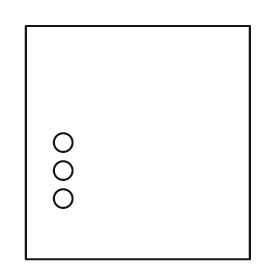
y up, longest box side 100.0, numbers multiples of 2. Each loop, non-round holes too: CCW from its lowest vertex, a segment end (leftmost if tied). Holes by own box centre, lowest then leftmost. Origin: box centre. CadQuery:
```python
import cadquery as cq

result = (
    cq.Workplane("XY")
    .moveTo(-48.0, -50.0)
    .lineTo(48.0, -50.0)
    .lineTo(48.0, 50.0)
    .lineTo(-48.0, 50.0)
    .close()
    .moveTo(-32.0, -24.0)
    .circle(4.0)
    .moveTo(-32.0, -12.0)
    .circle(4.0)
    .moveTo(-32.0, 0.0)
    .circle(4.0)
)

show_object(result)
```